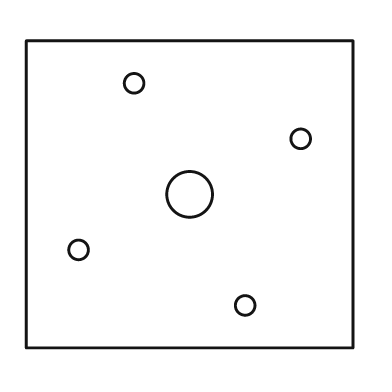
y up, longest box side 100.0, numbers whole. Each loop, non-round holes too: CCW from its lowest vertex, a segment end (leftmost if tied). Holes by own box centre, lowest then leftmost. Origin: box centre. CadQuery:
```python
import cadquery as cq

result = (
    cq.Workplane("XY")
    .moveTo(-50.0, -47.0)
    .lineTo(50.0, -47.0)
    .lineTo(50.0, 47.0)
    .lineTo(-50.0, 47.0)
    .close()
    .moveTo(17.0, -34.0)
    .circle(3.0)
    .moveTo(-34.0, -17.0)
    .circle(3.0)
    .moveTo(0.0, 0.0)
    .circle(7.0)
    .moveTo(34.0, 17.0)
    .circle(3.0)
    .moveTo(-17.0, 34.0)
    .circle(3.0)
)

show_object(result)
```